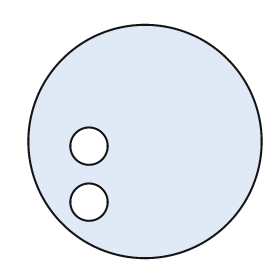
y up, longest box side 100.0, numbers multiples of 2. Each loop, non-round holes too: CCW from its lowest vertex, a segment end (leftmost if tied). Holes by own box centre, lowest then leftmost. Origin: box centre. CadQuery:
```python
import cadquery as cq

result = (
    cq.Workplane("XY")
    .moveTo(0.0, 0.0)
    .circle(50.0)
    .moveTo(-24.0, -26.0)
    .circle(8.0)
    .moveTo(-24.0, -2.0)
    .circle(8.0)
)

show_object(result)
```